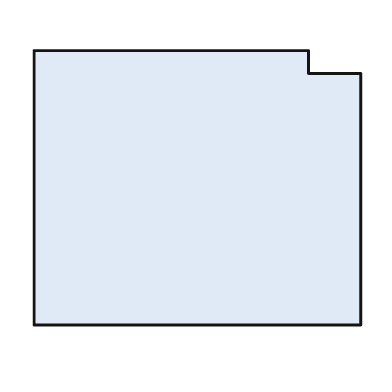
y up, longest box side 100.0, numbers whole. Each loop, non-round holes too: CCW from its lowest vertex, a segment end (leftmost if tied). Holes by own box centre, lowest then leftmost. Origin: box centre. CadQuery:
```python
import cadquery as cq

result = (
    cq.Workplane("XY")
    .moveTo(-50.0, -42.0)
    .lineTo(50.0, -42.0)
    .lineTo(50.0, 35.0)
    .lineTo(34.0, 35.0)
    .lineTo(34.0, 42.0)
    .lineTo(-50.0, 42.0)
    .close()
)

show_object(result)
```